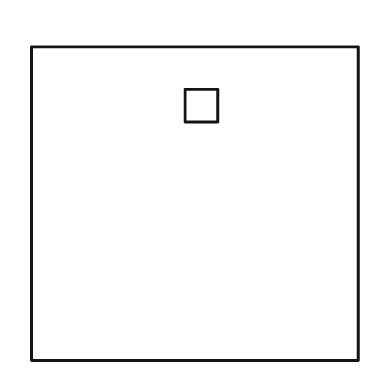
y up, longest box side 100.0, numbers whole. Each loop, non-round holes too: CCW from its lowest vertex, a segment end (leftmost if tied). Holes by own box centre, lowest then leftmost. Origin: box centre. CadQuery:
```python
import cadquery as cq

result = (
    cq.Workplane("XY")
    .moveTo(-50.0, -48.0)
    .lineTo(50.0, -48.0)
    .lineTo(50.0, 48.0)
    .lineTo(-50.0, 48.0)
    .close()
    .moveTo(-3.0, 25.0)
    .lineTo(7.0, 25.0)
    .lineTo(7.0, 35.0)
    .lineTo(-3.0, 35.0)
    .close()
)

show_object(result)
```